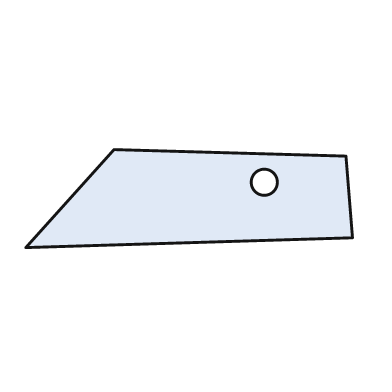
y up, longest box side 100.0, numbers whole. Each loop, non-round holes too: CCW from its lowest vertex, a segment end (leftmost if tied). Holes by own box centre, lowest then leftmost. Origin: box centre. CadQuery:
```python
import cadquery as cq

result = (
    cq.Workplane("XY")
    .moveTo(-50.0, -15.0)
    .lineTo(50.0, -12.0)
    .lineTo(48.0, 13.0)
    .lineTo(-23.0, 15.0)
    .close()
    .moveTo(23.0, 5.0)
    .circle(4.0)
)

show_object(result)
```